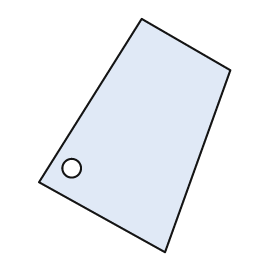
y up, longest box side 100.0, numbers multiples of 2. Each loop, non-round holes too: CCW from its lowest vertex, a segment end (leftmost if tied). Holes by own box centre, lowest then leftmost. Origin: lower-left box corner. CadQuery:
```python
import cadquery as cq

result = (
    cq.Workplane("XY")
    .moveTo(54.0, 0.0)
    .lineTo(82.0, 78.0)
    .lineTo(44.0, 100.0)
    .lineTo(0.0, 30.0)
    .close()
    .moveTo(14.0, 36.0)
    .circle(4.0)
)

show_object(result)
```